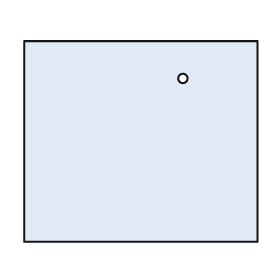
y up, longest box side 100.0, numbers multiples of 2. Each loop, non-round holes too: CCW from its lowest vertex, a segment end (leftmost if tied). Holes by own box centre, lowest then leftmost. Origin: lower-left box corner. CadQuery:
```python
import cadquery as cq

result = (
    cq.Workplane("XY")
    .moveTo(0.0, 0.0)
    .lineTo(100.0, 0.0)
    .lineTo(100.0, 86.0)
    .lineTo(0.0, 86.0)
    .close()
    .moveTo(68.0, 70.0)
    .circle(2.0)
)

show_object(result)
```